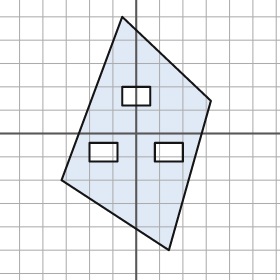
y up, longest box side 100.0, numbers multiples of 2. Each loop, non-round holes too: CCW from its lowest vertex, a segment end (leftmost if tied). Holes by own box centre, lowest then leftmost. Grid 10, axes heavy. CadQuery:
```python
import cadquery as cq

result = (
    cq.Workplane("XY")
    .moveTo(14.0, -50.0)
    .lineTo(32.0, 14.0)
    .lineTo(-6.0, 50.0)
    .lineTo(-32.0, -20.0)
    .close()
    .moveTo(-20.0, -12.0)
    .lineTo(-8.0, -12.0)
    .lineTo(-8.0, -4.0)
    .lineTo(-20.0, -4.0)
    .close()
    .moveTo(8.0, -12.0)
    .lineTo(20.0, -12.0)
    .lineTo(20.0, -4.0)
    .lineTo(8.0, -4.0)
    .close()
    .moveTo(-6.0, 12.0)
    .lineTo(6.0, 12.0)
    .lineTo(6.0, 20.0)
    .lineTo(-6.0, 20.0)
    .close()
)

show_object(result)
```